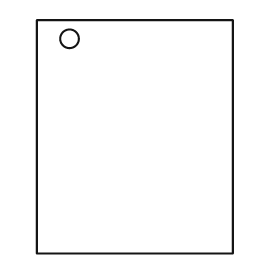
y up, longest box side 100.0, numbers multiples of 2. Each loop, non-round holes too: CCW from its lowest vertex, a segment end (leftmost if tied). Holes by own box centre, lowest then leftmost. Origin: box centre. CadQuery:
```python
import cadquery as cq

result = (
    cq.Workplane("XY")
    .moveTo(-42.0, -50.0)
    .lineTo(42.0, -50.0)
    .lineTo(42.0, 50.0)
    .lineTo(-42.0, 50.0)
    .close()
    .moveTo(-28.0, 42.0)
    .circle(4.0)
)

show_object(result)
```